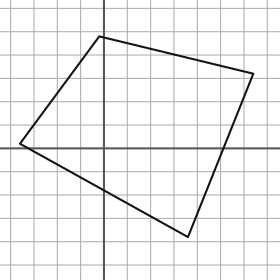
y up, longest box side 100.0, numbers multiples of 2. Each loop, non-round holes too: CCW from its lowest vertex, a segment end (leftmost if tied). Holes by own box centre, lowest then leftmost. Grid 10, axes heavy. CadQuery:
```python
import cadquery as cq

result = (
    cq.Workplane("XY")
    .moveTo(36.0, -38.0)
    .lineTo(64.0, 32.0)
    .lineTo(-2.0, 48.0)
    .lineTo(-36.0, 2.0)
    .close()
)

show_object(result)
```